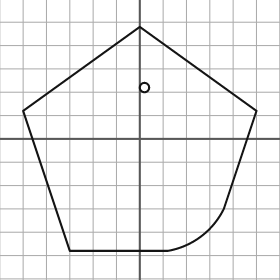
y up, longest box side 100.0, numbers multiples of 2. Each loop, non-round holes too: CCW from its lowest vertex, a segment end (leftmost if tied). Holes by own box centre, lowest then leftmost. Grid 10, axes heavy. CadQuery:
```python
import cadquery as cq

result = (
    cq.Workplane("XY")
    .moveTo(-30.0, -48.0)
    .lineTo(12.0, -48.0)
    .threePointArc((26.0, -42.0), (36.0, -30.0))
    .lineTo(50.0, 12.0)
    .lineTo(0.0, 48.0)
    .lineTo(-50.0, 12.0)
    .close()
    .moveTo(2.0, 22.0)
    .circle(2.0)
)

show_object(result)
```